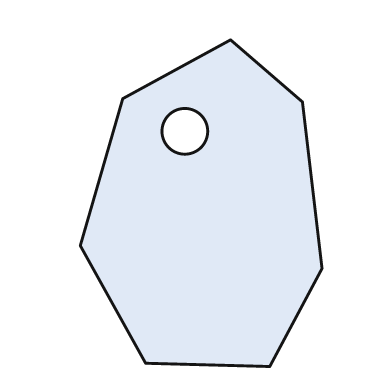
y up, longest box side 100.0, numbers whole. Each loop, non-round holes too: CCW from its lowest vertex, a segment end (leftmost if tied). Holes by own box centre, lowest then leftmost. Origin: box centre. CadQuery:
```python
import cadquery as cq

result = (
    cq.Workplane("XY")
    .moveTo(21.0, -50.0)
    .lineTo(37.0, -20.0)
    .lineTo(31.0, 31.0)
    .lineTo(9.0, 50.0)
    .lineTo(-24.0, 32.0)
    .lineTo(-37.0, -13.0)
    .lineTo(-17.0, -49.0)
    .close()
    .moveTo(-5.0, 22.0)
    .circle(7.0)
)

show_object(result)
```